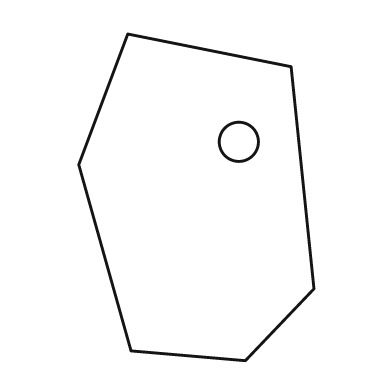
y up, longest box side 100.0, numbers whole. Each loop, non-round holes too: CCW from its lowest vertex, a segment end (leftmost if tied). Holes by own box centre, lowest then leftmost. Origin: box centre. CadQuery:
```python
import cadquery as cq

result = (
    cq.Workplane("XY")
    .moveTo(15.0, -50.0)
    .lineTo(36.0, -28.0)
    .lineTo(29.0, 40.0)
    .lineTo(-21.0, 50.0)
    .lineTo(-36.0, 10.0)
    .lineTo(-20.0, -47.0)
    .close()
    .moveTo(13.0, 17.0)
    .circle(6.0)
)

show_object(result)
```